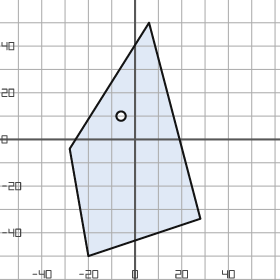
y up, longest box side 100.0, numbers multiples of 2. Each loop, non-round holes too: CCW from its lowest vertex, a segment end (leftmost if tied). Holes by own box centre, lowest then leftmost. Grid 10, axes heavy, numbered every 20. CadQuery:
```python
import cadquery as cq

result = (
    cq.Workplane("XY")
    .moveTo(-20.0, -50.0)
    .lineTo(28.0, -34.0)
    .lineTo(6.0, 50.0)
    .lineTo(-28.0, -4.0)
    .close()
    .moveTo(-6.0, 10.0)
    .circle(2.0)
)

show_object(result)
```